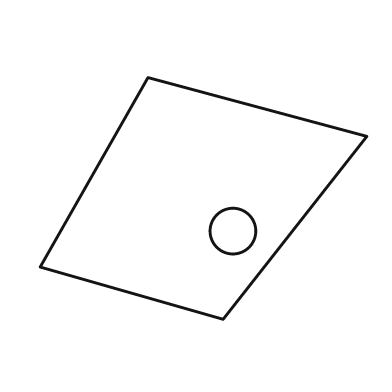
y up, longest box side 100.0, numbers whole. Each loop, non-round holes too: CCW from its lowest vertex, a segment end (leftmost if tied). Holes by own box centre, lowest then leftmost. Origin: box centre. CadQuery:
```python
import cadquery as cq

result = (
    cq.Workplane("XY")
    .moveTo(6.0, -37.0)
    .lineTo(50.0, 19.0)
    .lineTo(-17.0, 37.0)
    .lineTo(-50.0, -21.0)
    .close()
    .moveTo(9.0, -10.0)
    .circle(7.0)
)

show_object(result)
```